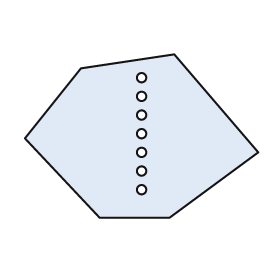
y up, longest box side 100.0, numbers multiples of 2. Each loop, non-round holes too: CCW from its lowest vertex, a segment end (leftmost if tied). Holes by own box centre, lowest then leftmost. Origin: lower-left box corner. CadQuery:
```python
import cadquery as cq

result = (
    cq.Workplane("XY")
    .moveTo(32.0, 0.0)
    .lineTo(62.0, 0.0)
    .lineTo(100.0, 28.0)
    .lineTo(64.0, 70.0)
    .lineTo(24.0, 64.0)
    .lineTo(0.0, 34.0)
    .close()
    .moveTo(50.0, 12.0)
    .circle(2.0)
    .moveTo(50.0, 20.0)
    .circle(2.0)
    .moveTo(50.0, 28.0)
    .circle(2.0)
    .moveTo(50.0, 36.0)
    .circle(2.0)
    .moveTo(50.0, 44.0)
    .circle(2.0)
    .moveTo(50.0, 52.0)
    .circle(2.0)
    .moveTo(50.0, 60.0)
    .circle(2.0)
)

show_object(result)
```